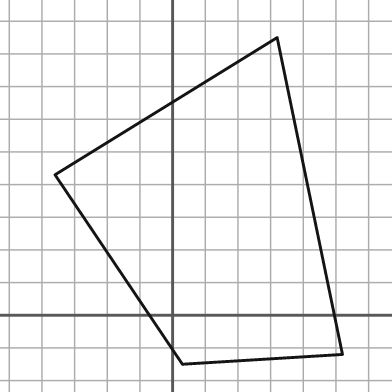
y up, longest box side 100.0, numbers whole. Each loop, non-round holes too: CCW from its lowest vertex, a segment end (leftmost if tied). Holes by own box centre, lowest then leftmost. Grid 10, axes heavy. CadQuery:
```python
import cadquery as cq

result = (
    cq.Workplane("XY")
    .moveTo(3.0, -15.0)
    .lineTo(52.0, -12.0)
    .lineTo(32.0, 85.0)
    .lineTo(-36.0, 43.0)
    .close()
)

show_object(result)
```